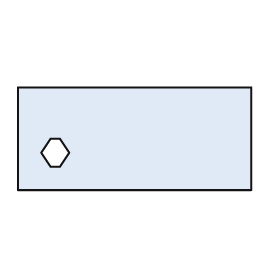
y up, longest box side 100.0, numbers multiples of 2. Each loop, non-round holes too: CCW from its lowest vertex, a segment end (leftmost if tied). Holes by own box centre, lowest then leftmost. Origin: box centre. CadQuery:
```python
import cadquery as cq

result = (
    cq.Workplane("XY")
    .moveTo(-50.0, -22.0)
    .lineTo(50.0, -22.0)
    .lineTo(50.0, 22.0)
    .lineTo(-50.0, 22.0)
    .close()
    .moveTo(-36.0, -12.0)
    .lineTo(-32.0, -12.0)
    .lineTo(-28.0, -6.0)
    .lineTo(-32.0, 0.0)
    .lineTo(-36.0, 0.0)
    .lineTo(-40.0, -6.0)
    .close()
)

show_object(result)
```